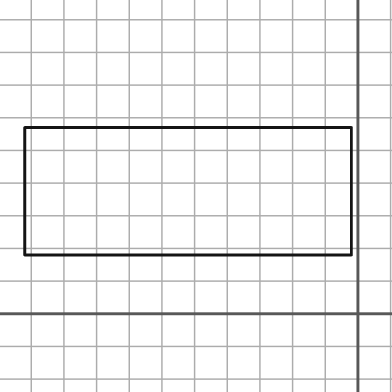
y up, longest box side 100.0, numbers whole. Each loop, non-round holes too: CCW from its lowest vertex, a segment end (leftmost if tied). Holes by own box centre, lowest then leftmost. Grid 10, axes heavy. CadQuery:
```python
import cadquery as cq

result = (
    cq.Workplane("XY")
    .moveTo(-102.0, 18.0)
    .lineTo(-2.0, 18.0)
    .lineTo(-2.0, 57.0)
    .lineTo(-102.0, 57.0)
    .close()
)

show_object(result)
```